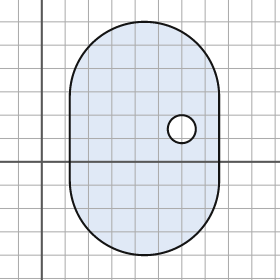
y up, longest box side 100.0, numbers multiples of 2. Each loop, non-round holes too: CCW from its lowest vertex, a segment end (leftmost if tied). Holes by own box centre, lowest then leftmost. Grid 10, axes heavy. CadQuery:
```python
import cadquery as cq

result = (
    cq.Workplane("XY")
    .moveTo(12.0, -8.0)
    .threePointArc((44.0, -40.0), (76.0, -8.0))
    .lineTo(76.0, 28.0)
    .threePointArc((44.0, 60.0), (12.0, 28.0))
    .close()
    .moveTo(60.0, 14.0)
    .circle(6.0)
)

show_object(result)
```